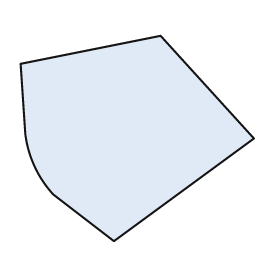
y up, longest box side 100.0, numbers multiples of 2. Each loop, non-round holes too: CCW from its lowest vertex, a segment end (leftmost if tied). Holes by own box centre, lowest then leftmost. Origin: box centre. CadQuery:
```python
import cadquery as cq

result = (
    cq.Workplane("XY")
    .moveTo(-10.0, -44.0)
    .lineTo(50.0, 0.0)
    .lineTo(10.0, 44.0)
    .lineTo(-50.0, 32.0)
    .lineTo(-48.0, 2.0)
    .threePointArc((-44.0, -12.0), (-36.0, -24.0))
    .close()
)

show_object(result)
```